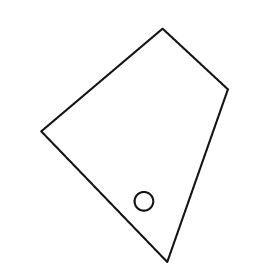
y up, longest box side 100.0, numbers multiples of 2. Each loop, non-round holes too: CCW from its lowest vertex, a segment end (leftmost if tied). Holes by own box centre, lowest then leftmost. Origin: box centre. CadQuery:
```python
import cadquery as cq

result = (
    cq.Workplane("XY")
    .moveTo(14.0, -50.0)
    .lineTo(40.0, 24.0)
    .lineTo(12.0, 50.0)
    .lineTo(-40.0, 6.0)
    .close()
    .moveTo(4.0, -24.0)
    .circle(4.0)
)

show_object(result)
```